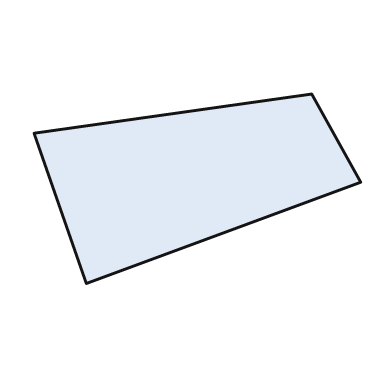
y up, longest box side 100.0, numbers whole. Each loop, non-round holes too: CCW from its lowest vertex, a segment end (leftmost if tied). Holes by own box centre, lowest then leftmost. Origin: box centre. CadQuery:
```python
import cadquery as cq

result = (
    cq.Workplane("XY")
    .moveTo(-34.0, -29.0)
    .lineTo(50.0, 2.0)
    .lineTo(35.0, 29.0)
    .lineTo(-50.0, 17.0)
    .close()
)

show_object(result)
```